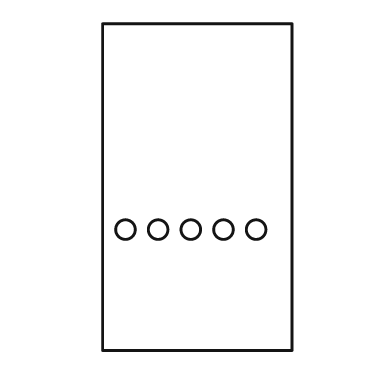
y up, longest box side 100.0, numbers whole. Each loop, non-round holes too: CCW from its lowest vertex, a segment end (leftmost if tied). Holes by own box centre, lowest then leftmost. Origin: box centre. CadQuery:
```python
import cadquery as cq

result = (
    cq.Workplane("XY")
    .moveTo(-29.0, -50.0)
    .lineTo(29.0, -50.0)
    .lineTo(29.0, 50.0)
    .lineTo(-29.0, 50.0)
    .close()
    .moveTo(-22.0, -13.0)
    .circle(3.0)
    .moveTo(-12.0, -13.0)
    .circle(3.0)
    .moveTo(-2.0, -13.0)
    .circle(3.0)
    .moveTo(8.0, -13.0)
    .circle(3.0)
    .moveTo(18.0, -13.0)
    .circle(3.0)
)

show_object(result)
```